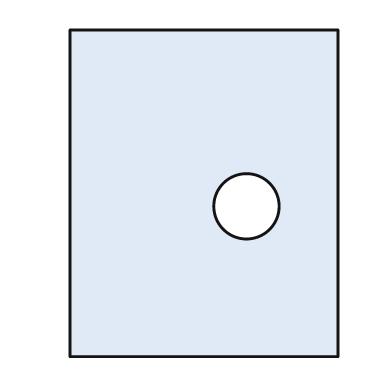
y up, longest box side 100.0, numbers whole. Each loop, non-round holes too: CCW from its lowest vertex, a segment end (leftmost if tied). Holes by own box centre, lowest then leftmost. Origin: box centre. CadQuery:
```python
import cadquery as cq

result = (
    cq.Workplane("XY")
    .moveTo(-41.0, -50.0)
    .lineTo(41.0, -50.0)
    .lineTo(41.0, 50.0)
    .lineTo(-41.0, 50.0)
    .close()
    .moveTo(13.0, -4.0)
    .circle(10.0)
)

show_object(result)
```